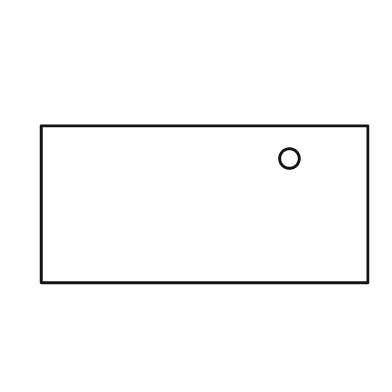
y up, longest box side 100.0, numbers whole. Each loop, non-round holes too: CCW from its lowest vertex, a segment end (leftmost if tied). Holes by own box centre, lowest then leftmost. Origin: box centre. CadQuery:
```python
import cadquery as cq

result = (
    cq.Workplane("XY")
    .moveTo(-50.0, -24.0)
    .lineTo(50.0, -24.0)
    .lineTo(50.0, 24.0)
    .lineTo(-50.0, 24.0)
    .close()
    .moveTo(26.0, 14.0)
    .circle(3.0)
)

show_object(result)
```